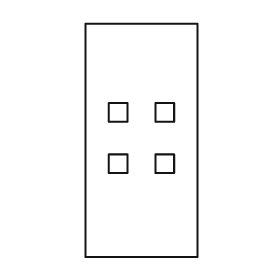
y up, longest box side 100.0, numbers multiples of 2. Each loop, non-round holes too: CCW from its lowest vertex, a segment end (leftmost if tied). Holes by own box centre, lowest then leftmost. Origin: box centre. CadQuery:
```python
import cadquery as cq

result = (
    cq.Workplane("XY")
    .moveTo(-24.0, -50.0)
    .lineTo(24.0, -50.0)
    .lineTo(24.0, 50.0)
    .lineTo(-24.0, 50.0)
    .close()
    .moveTo(-14.0, -14.0)
    .lineTo(-6.0, -14.0)
    .lineTo(-6.0, -6.0)
    .lineTo(-14.0, -6.0)
    .close()
    .moveTo(6.0, -14.0)
    .lineTo(14.0, -14.0)
    .lineTo(14.0, -6.0)
    .lineTo(6.0, -6.0)
    .close()
    .moveTo(-14.0, 8.0)
    .lineTo(-6.0, 8.0)
    .lineTo(-6.0, 16.0)
    .lineTo(-14.0, 16.0)
    .close()
    .moveTo(6.0, 8.0)
    .lineTo(14.0, 8.0)
    .lineTo(14.0, 16.0)
    .lineTo(6.0, 16.0)
    .close()
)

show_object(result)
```